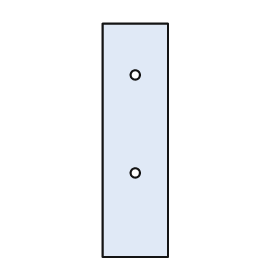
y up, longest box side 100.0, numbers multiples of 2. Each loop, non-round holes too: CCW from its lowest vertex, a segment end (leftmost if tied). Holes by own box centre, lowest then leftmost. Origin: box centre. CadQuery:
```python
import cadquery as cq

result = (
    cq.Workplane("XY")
    .moveTo(-14.0, -50.0)
    .lineTo(14.0, -50.0)
    .lineTo(14.0, 50.0)
    .lineTo(-14.0, 50.0)
    .close()
    .moveTo(0.0, -14.0)
    .circle(2.0)
    .moveTo(0.0, 28.0)
    .circle(2.0)
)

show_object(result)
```